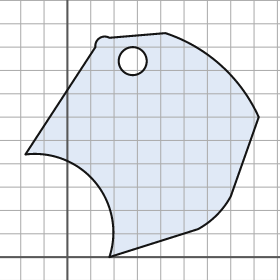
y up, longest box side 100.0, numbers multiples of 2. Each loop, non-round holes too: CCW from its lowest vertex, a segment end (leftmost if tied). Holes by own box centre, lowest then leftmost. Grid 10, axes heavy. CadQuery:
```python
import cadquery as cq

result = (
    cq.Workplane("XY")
    .moveTo(18.0, 0.0)
    .lineTo(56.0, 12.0)
    .threePointArc((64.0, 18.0), (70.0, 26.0))
    .lineTo(82.0, 60.0)
    .threePointArc((66.0, 82.0), (42.0, 96.0))
    .lineTo(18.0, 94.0)
    .threePointArc((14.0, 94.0), (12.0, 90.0))
    .lineTo(-18.0, 44.0)
    .threePointArc((12.0, 32.0), (18.0, 0.0))
    .close()
    .moveTo(28.0, 84.0)
    .circle(6.0)
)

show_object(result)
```